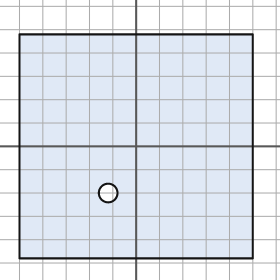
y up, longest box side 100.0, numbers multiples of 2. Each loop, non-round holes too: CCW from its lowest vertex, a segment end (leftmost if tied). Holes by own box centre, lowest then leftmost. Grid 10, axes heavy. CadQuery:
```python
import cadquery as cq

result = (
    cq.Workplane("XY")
    .moveTo(-50.0, -48.0)
    .lineTo(50.0, -48.0)
    .lineTo(50.0, 48.0)
    .lineTo(-50.0, 48.0)
    .close()
    .moveTo(-12.0, -20.0)
    .circle(4.0)
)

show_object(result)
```